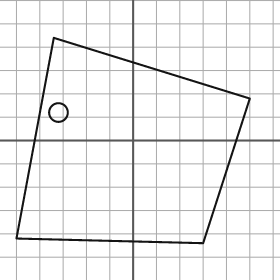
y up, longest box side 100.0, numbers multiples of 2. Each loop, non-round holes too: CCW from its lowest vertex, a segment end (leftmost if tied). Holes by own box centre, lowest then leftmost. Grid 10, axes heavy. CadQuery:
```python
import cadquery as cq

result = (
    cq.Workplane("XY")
    .moveTo(30.0, -44.0)
    .lineTo(50.0, 18.0)
    .lineTo(-34.0, 44.0)
    .lineTo(-50.0, -42.0)
    .close()
    .moveTo(-32.0, 12.0)
    .circle(4.0)
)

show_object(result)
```